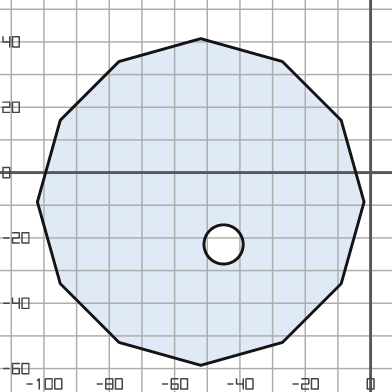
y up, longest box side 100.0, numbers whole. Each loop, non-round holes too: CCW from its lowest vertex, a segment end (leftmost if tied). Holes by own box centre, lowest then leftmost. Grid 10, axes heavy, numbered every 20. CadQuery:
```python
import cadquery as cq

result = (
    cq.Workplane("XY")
    .moveTo(-52.0, -59.0)
    .lineTo(-27.0, -52.0)
    .lineTo(-9.0, -34.0)
    .lineTo(-2.0, -9.0)
    .lineTo(-9.0, 16.0)
    .lineTo(-27.0, 34.0)
    .lineTo(-52.0, 41.0)
    .lineTo(-77.0, 34.0)
    .lineTo(-95.0, 16.0)
    .lineTo(-102.0, -9.0)
    .lineTo(-95.0, -34.0)
    .lineTo(-77.0, -52.0)
    .close()
    .moveTo(-45.0, -22.0)
    .circle(6.0)
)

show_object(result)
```